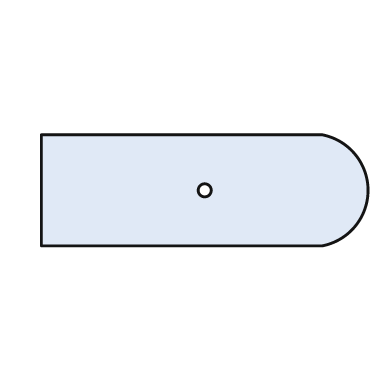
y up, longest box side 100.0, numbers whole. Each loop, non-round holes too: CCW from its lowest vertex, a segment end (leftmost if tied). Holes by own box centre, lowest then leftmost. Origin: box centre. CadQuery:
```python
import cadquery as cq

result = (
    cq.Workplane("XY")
    .moveTo(-50.0, -17.0)
    .lineTo(36.0, -17.0)
    .threePointArc((50.0, 0.0), (36.0, 17.0))
    .lineTo(-50.0, 17.0)
    .close()
    .moveTo(0.0, 0.0)
    .circle(2.0)
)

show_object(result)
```